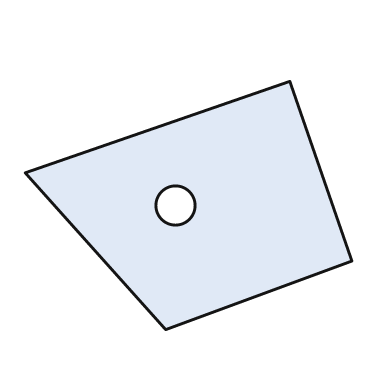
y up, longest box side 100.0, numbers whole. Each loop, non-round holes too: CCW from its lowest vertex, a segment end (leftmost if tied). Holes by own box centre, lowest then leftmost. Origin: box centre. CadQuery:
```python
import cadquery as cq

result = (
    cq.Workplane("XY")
    .moveTo(-7.0, -38.0)
    .lineTo(50.0, -17.0)
    .lineTo(31.0, 38.0)
    .lineTo(-50.0, 10.0)
    .close()
    .moveTo(-4.0, 0.0)
    .circle(6.0)
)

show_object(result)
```